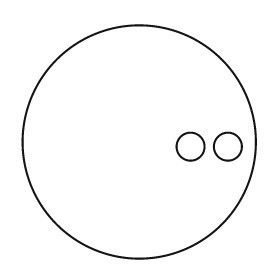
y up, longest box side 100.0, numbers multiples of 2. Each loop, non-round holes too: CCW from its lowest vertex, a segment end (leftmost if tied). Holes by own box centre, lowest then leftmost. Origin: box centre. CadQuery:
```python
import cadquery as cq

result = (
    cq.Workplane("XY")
    .moveTo(0.0, 0.0)
    .circle(50.0)
    .moveTo(22.0, -2.0)
    .circle(6.0)
    .moveTo(38.0, -2.0)
    .circle(6.0)
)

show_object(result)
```